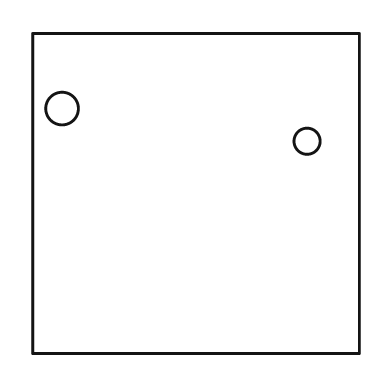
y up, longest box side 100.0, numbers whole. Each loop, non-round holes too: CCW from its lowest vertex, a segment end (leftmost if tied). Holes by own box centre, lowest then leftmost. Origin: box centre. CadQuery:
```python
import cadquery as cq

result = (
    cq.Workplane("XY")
    .moveTo(-50.0, -49.0)
    .lineTo(50.0, -49.0)
    .lineTo(50.0, 49.0)
    .lineTo(-50.0, 49.0)
    .close()
    .moveTo(34.0, 16.0)
    .circle(4.0)
    .moveTo(-41.0, 26.0)
    .circle(5.0)
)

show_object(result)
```